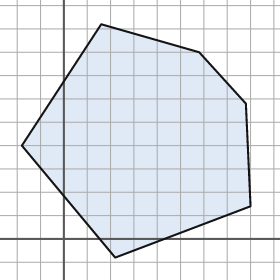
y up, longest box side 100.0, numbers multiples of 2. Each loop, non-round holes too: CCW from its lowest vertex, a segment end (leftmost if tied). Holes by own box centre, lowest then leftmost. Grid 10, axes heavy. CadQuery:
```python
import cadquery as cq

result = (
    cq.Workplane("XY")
    .moveTo(22.0, -8.0)
    .lineTo(80.0, 14.0)
    .lineTo(78.0, 58.0)
    .lineTo(58.0, 80.0)
    .lineTo(16.0, 92.0)
    .lineTo(-18.0, 40.0)
    .close()
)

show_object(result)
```